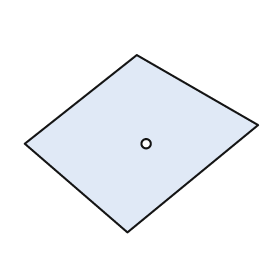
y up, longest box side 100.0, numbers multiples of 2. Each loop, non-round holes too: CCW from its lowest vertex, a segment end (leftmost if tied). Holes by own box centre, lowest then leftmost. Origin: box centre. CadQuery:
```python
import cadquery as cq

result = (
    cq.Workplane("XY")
    .moveTo(-6.0, -38.0)
    .lineTo(50.0, 8.0)
    .lineTo(-2.0, 38.0)
    .lineTo(-50.0, 0.0)
    .close()
    .moveTo(2.0, 0.0)
    .circle(2.0)
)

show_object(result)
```